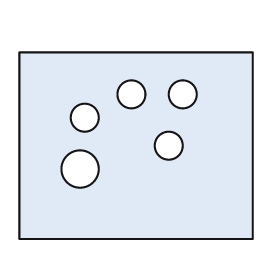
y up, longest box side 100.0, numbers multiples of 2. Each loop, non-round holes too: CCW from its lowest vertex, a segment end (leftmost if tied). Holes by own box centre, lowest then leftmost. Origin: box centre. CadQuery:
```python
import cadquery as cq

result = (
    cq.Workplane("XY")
    .moveTo(-50.0, -40.0)
    .lineTo(50.0, -40.0)
    .lineTo(50.0, 40.0)
    .lineTo(-50.0, 40.0)
    .close()
    .moveTo(-24.0, -10.0)
    .circle(8.0)
    .moveTo(14.0, 0.0)
    .circle(6.0)
    .moveTo(-22.0, 12.0)
    .circle(6.0)
    .moveTo(-2.0, 22.0)
    .circle(6.0)
    .moveTo(20.0, 22.0)
    .circle(6.0)
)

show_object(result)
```